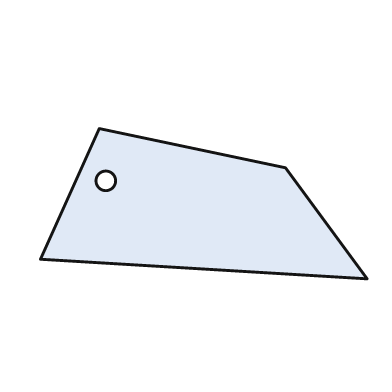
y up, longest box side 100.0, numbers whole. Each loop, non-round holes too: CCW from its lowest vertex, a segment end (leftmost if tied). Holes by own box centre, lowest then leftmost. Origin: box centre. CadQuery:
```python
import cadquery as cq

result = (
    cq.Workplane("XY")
    .moveTo(50.0, -23.0)
    .lineTo(25.0, 11.0)
    .lineTo(-32.0, 23.0)
    .lineTo(-50.0, -17.0)
    .close()
    .moveTo(-30.0, 7.0)
    .circle(3.0)
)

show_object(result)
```